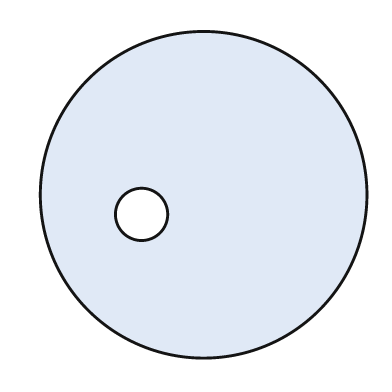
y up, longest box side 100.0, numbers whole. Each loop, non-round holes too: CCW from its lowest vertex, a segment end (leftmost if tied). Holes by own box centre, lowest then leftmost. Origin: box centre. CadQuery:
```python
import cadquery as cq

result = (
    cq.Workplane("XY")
    .moveTo(0.0, 0.0)
    .circle(50.0)
    .moveTo(-19.0, -6.0)
    .circle(8.0)
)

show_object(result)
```